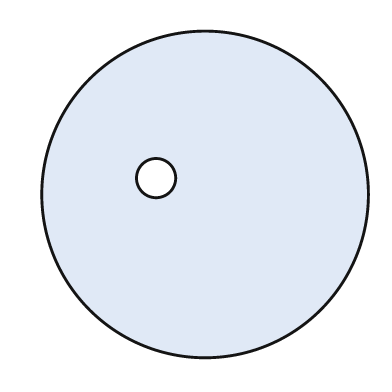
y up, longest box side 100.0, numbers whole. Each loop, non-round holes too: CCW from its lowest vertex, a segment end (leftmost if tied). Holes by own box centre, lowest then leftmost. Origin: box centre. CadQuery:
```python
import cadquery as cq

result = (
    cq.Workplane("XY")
    .moveTo(0.0, 0.0)
    .circle(50.0)
    .moveTo(-15.0, 5.0)
    .circle(6.0)
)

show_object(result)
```